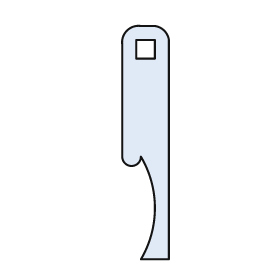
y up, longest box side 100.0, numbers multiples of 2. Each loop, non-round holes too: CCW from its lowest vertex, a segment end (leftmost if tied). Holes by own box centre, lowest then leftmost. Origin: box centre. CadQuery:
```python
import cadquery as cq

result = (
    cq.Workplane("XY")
    .moveTo(-2.0, -50.0)
    .lineTo(10.0, -50.0)
    .lineTo(10.0, 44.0)
    .threePointArc((8.0, 48.0), (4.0, 50.0))
    .lineTo(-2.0, 50.0)
    .threePointArc((-8.0, 48.0), (-10.0, 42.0))
    .lineTo(-10.0, -6.0)
    .threePointArc((-6.0, -10.0), (-2.0, -6.0))
    .threePointArc((4.0, -28.0), (-2.0, -50.0))
    .close()
    .moveTo(-4.0, 36.0)
    .lineTo(4.0, 36.0)
    .lineTo(4.0, 44.0)
    .lineTo(-4.0, 44.0)
    .close()
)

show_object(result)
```